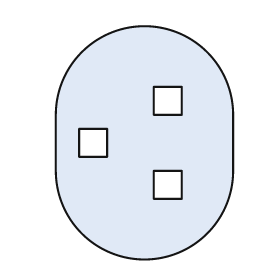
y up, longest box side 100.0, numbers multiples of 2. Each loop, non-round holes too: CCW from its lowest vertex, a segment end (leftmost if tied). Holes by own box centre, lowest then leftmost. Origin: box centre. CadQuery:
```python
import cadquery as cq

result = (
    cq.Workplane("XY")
    .moveTo(-38.0, -12.0)
    .threePointArc((0.0, -50.0), (38.0, -12.0))
    .lineTo(38.0, 12.0)
    .threePointArc((0.0, 50.0), (-38.0, 12.0))
    .close()
    .moveTo(4.0, -24.0)
    .lineTo(16.0, -24.0)
    .lineTo(16.0, -12.0)
    .lineTo(4.0, -12.0)
    .close()
    .moveTo(-28.0, -6.0)
    .lineTo(-16.0, -6.0)
    .lineTo(-16.0, 6.0)
    .lineTo(-28.0, 6.0)
    .close()
    .moveTo(4.0, 12.0)
    .lineTo(16.0, 12.0)
    .lineTo(16.0, 24.0)
    .lineTo(4.0, 24.0)
    .close()
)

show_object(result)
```